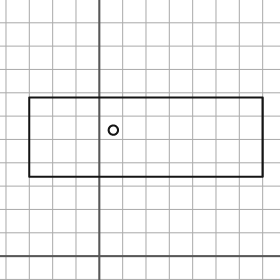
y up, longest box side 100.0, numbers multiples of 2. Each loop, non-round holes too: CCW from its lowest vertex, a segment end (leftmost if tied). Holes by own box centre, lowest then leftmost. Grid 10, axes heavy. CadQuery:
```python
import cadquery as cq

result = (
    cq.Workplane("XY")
    .moveTo(-30.0, 34.0)
    .lineTo(70.0, 34.0)
    .lineTo(70.0, 68.0)
    .lineTo(-30.0, 68.0)
    .close()
    .moveTo(6.0, 54.0)
    .circle(2.0)
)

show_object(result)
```